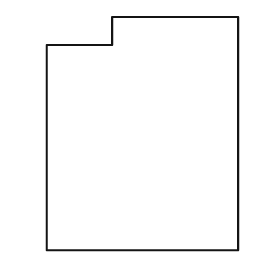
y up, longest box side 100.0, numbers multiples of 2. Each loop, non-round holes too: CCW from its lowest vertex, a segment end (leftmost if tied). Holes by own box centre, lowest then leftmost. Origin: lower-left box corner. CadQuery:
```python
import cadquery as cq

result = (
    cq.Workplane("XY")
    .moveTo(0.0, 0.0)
    .lineTo(82.0, 0.0)
    .lineTo(82.0, 100.0)
    .lineTo(28.0, 100.0)
    .lineTo(28.0, 88.0)
    .lineTo(0.0, 88.0)
    .close()
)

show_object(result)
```